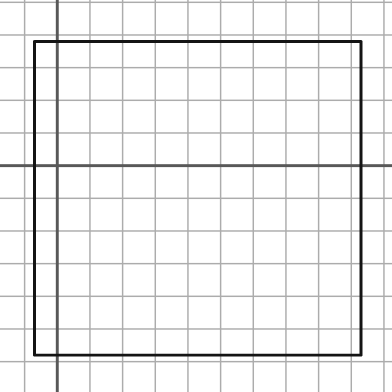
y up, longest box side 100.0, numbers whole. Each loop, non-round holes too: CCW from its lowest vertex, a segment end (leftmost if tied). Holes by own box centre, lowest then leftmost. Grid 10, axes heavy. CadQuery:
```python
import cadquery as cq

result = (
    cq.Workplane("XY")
    .moveTo(-7.0, -58.0)
    .lineTo(93.0, -58.0)
    .lineTo(93.0, 38.0)
    .lineTo(-7.0, 38.0)
    .close()
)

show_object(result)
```